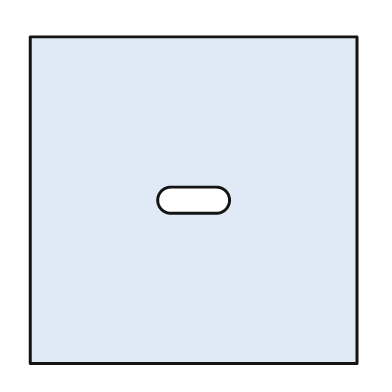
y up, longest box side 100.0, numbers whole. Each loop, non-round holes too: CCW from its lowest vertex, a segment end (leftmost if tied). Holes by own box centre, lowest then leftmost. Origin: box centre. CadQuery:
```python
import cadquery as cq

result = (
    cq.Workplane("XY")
    .moveTo(-50.0, -50.0)
    .lineTo(50.0, -50.0)
    .lineTo(50.0, 50.0)
    .lineTo(-50.0, 50.0)
    .close()
    .moveTo(-7.0, -4.0)
    .lineTo(7.0, -4.0)
    .threePointArc((11.0, 0.0), (7.0, 4.0))
    .lineTo(-7.0, 4.0)
    .threePointArc((-11.0, 0.0), (-7.0, -4.0))
    .close()
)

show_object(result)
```